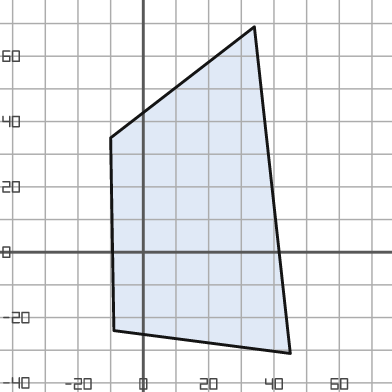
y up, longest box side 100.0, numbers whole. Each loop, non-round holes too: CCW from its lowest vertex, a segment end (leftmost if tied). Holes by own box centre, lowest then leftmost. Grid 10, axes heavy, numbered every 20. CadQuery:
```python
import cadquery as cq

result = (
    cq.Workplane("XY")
    .moveTo(45.0, -31.0)
    .lineTo(34.0, 69.0)
    .lineTo(-10.0, 35.0)
    .lineTo(-9.0, -24.0)
    .close()
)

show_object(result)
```